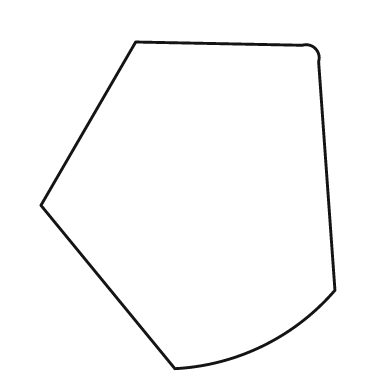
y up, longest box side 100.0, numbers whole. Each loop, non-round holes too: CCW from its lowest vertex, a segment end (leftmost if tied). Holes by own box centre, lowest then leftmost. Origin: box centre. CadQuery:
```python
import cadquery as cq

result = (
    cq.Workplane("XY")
    .moveTo(-4.0, -50.0)
    .threePointArc((23.0, -43.0), (45.0, -26.0))
    .lineTo(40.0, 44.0)
    .threePointArc((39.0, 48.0), (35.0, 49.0))
    .lineTo(-16.0, 50.0)
    .lineTo(-45.0, 0.0)
    .close()
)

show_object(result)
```